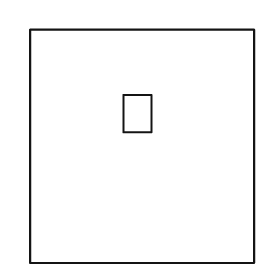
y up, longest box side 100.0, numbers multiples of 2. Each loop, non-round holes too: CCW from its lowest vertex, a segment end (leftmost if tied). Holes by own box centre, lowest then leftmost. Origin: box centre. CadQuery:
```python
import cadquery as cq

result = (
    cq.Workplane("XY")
    .moveTo(-48.0, -50.0)
    .lineTo(48.0, -50.0)
    .lineTo(48.0, 50.0)
    .lineTo(-48.0, 50.0)
    .close()
    .moveTo(-8.0, 6.0)
    .lineTo(4.0, 6.0)
    .lineTo(4.0, 22.0)
    .lineTo(-8.0, 22.0)
    .close()
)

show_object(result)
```